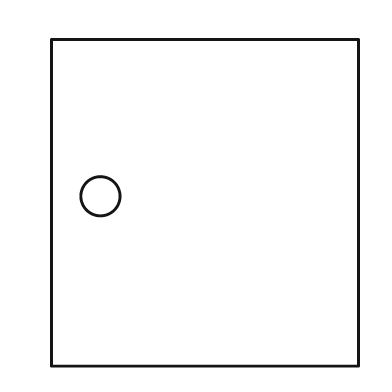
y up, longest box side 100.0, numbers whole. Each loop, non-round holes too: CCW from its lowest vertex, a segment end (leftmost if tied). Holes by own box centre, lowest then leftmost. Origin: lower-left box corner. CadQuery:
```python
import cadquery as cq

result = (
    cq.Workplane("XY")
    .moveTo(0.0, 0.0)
    .lineTo(94.0, 0.0)
    .lineTo(94.0, 100.0)
    .lineTo(0.0, 100.0)
    .close()
    .moveTo(15.0, 52.0)
    .circle(6.0)
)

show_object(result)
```